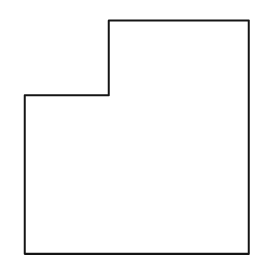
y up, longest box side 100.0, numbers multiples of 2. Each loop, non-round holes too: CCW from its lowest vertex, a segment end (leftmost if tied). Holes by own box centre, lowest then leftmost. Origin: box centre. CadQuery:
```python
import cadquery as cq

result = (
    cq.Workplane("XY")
    .moveTo(-48.0, -50.0)
    .lineTo(48.0, -50.0)
    .lineTo(48.0, 50.0)
    .lineTo(-12.0, 50.0)
    .lineTo(-12.0, 18.0)
    .lineTo(-48.0, 18.0)
    .close()
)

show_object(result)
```